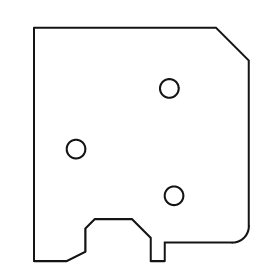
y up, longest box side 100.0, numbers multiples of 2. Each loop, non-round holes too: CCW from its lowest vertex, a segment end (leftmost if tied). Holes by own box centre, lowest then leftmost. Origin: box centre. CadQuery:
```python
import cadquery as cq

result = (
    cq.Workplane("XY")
    .moveTo(-46.0, -50.0)
    .lineTo(-32.0, -50.0)
    .lineTo(-24.0, -46.0)
    .lineTo(-24.0, -36.0)
    .lineTo(-20.0, -32.0)
    .lineTo(-4.0, -32.0)
    .lineTo(4.0, -40.0)
    .lineTo(4.0, -50.0)
    .lineTo(10.0, -50.0)
    .lineTo(10.0, -42.0)
    .lineTo(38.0, -42.0)
    .threePointArc((44.0, -40.0), (46.0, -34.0))
    .lineTo(46.0, 36.0)
    .lineTo(32.0, 50.0)
    .lineTo(-46.0, 50.0)
    .close()
    .moveTo(14.0, -22.0)
    .circle(4.0)
    .moveTo(-28.0, -2.0)
    .circle(4.0)
    .moveTo(12.0, 24.0)
    .circle(4.0)
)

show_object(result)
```